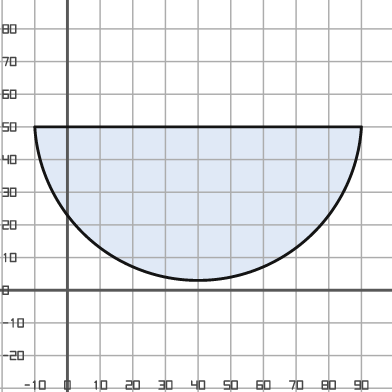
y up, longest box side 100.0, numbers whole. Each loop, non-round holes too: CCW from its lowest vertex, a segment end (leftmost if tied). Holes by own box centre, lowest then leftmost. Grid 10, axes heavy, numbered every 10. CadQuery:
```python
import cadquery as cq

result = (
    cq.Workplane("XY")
    .moveTo(-10.0, 50.0)
    .threePointArc((40.0, 3.0), (90.0, 50.0))
    .close()
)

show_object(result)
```